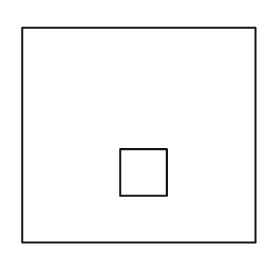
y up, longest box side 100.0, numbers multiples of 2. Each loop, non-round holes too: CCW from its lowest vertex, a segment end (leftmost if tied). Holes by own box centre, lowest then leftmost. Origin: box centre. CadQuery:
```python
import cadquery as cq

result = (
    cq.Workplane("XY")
    .moveTo(-50.0, -46.0)
    .lineTo(50.0, -46.0)
    .lineTo(50.0, 46.0)
    .lineTo(-50.0, 46.0)
    .close()
    .moveTo(-8.0, -26.0)
    .lineTo(12.0, -26.0)
    .lineTo(12.0, -6.0)
    .lineTo(-8.0, -6.0)
    .close()
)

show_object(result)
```